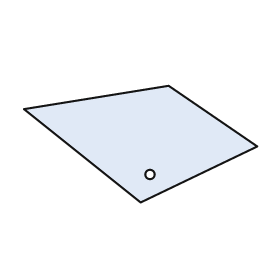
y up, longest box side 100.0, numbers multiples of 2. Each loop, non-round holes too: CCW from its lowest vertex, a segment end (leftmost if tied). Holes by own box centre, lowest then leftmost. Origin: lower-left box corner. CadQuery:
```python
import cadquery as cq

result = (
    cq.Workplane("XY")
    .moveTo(50.0, 0.0)
    .lineTo(100.0, 24.0)
    .lineTo(62.0, 50.0)
    .lineTo(0.0, 40.0)
    .close()
    .moveTo(54.0, 12.0)
    .circle(2.0)
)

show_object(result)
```